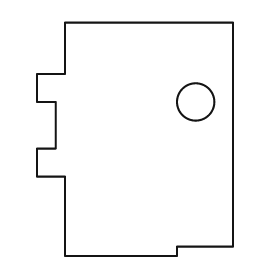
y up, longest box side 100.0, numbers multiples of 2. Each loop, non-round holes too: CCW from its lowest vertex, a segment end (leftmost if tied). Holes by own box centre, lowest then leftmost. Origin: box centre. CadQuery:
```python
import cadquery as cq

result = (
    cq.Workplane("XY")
    .moveTo(-30.0, -50.0)
    .lineTo(18.0, -50.0)
    .lineTo(18.0, -46.0)
    .lineTo(42.0, -46.0)
    .lineTo(42.0, 50.0)
    .lineTo(-30.0, 50.0)
    .lineTo(-30.0, 28.0)
    .lineTo(-42.0, 28.0)
    .lineTo(-42.0, 16.0)
    .lineTo(-34.0, 16.0)
    .lineTo(-34.0, -4.0)
    .lineTo(-42.0, -4.0)
    .lineTo(-42.0, -16.0)
    .lineTo(-30.0, -16.0)
    .close()
    .moveTo(26.0, 16.0)
    .circle(8.0)
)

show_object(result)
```